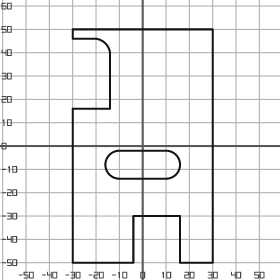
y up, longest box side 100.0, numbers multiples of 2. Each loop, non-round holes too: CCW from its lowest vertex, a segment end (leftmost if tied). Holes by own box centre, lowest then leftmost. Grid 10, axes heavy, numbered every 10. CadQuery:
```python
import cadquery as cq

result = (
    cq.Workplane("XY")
    .moveTo(-30.0, -50.0)
    .lineTo(-4.0, -50.0)
    .lineTo(-4.0, -30.0)
    .lineTo(16.0, -30.0)
    .lineTo(16.0, -50.0)
    .lineTo(30.0, -50.0)
    .lineTo(30.0, 50.0)
    .lineTo(-30.0, 50.0)
    .lineTo(-30.0, 46.0)
    .lineTo(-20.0, 46.0)
    .threePointArc((-16.0, 44.0), (-14.0, 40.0))
    .lineTo(-14.0, 16.0)
    .lineTo(-30.0, 16.0)
    .close()
    .moveTo(-10.0, -14.0)
    .lineTo(10.0, -14.0)
    .threePointArc((16.0, -8.0), (10.0, -2.0))
    .lineTo(-10.0, -2.0)
    .threePointArc((-16.0, -8.0), (-10.0, -14.0))
    .close()
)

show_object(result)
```